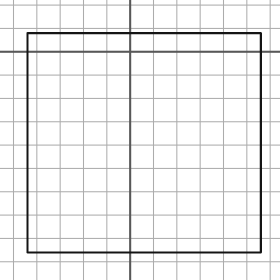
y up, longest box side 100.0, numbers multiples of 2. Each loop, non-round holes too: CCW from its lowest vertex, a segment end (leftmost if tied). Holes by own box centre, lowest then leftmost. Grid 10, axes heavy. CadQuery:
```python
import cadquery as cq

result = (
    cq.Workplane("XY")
    .moveTo(-44.0, -86.0)
    .lineTo(56.0, -86.0)
    .lineTo(56.0, 8.0)
    .lineTo(-44.0, 8.0)
    .close()
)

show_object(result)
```